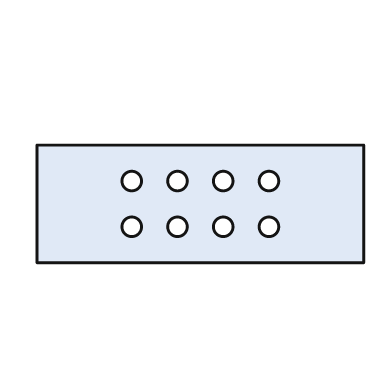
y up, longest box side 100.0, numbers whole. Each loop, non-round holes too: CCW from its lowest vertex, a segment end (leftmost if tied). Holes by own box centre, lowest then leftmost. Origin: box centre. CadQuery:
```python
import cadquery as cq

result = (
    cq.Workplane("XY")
    .moveTo(-50.0, -18.0)
    .lineTo(50.0, -18.0)
    .lineTo(50.0, 18.0)
    .lineTo(-50.0, 18.0)
    .close()
    .moveTo(-21.0, -7.0)
    .circle(3.0)
    .moveTo(-7.0, -7.0)
    .circle(3.0)
    .moveTo(7.0, -7.0)
    .circle(3.0)
    .moveTo(21.0, -7.0)
    .circle(3.0)
    .moveTo(-21.0, 7.0)
    .circle(3.0)
    .moveTo(-7.0, 7.0)
    .circle(3.0)
    .moveTo(7.0, 7.0)
    .circle(3.0)
    .moveTo(21.0, 7.0)
    .circle(3.0)
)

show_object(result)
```